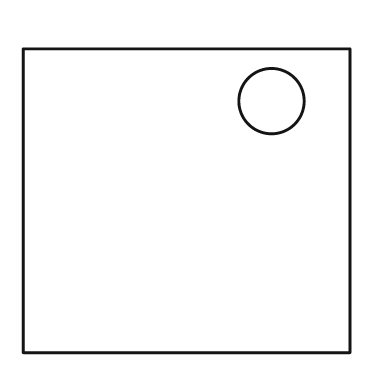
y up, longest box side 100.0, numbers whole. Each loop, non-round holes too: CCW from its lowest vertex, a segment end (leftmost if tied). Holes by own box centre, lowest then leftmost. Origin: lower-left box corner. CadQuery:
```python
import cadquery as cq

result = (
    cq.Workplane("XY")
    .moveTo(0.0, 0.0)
    .lineTo(100.0, 0.0)
    .lineTo(100.0, 93.0)
    .lineTo(0.0, 93.0)
    .close()
    .moveTo(76.0, 77.0)
    .circle(10.0)
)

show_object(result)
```